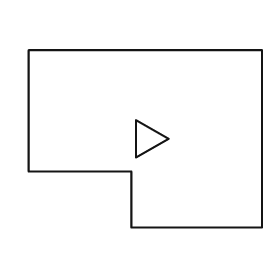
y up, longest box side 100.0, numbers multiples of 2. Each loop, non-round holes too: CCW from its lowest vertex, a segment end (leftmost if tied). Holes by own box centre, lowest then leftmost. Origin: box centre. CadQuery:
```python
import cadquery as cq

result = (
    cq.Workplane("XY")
    .moveTo(-6.0, -38.0)
    .lineTo(50.0, -38.0)
    .lineTo(50.0, 38.0)
    .lineTo(-50.0, 38.0)
    .lineTo(-50.0, -14.0)
    .lineTo(-6.0, -14.0)
    .close()
    .moveTo(-4.0, -8.0)
    .lineTo(10.0, 0.0)
    .lineTo(-4.0, 8.0)
    .close()
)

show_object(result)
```